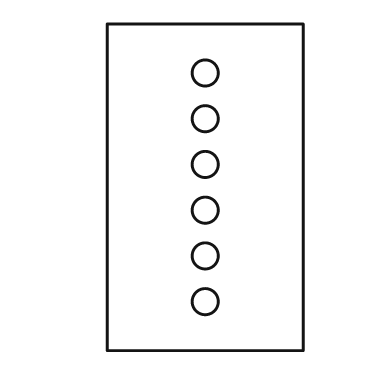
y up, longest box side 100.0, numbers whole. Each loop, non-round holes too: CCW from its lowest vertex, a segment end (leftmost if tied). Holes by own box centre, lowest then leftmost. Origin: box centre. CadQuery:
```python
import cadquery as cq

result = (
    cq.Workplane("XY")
    .moveTo(-30.0, -50.0)
    .lineTo(30.0, -50.0)
    .lineTo(30.0, 50.0)
    .lineTo(-30.0, 50.0)
    .close()
    .moveTo(0.0, -35.0)
    .circle(4.0)
    .moveTo(0.0, -21.0)
    .circle(4.0)
    .moveTo(0.0, -7.0)
    .circle(4.0)
    .moveTo(0.0, 7.0)
    .circle(4.0)
    .moveTo(0.0, 21.0)
    .circle(4.0)
    .moveTo(0.0, 35.0)
    .circle(4.0)
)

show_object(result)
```